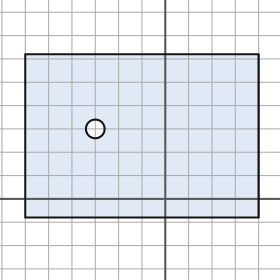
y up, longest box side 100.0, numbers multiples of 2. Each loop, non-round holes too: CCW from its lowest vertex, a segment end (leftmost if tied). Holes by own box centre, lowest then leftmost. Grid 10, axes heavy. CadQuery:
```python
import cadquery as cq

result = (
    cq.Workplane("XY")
    .moveTo(-60.0, -8.0)
    .lineTo(40.0, -8.0)
    .lineTo(40.0, 62.0)
    .lineTo(-60.0, 62.0)
    .close()
    .moveTo(-30.0, 30.0)
    .circle(4.0)
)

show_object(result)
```